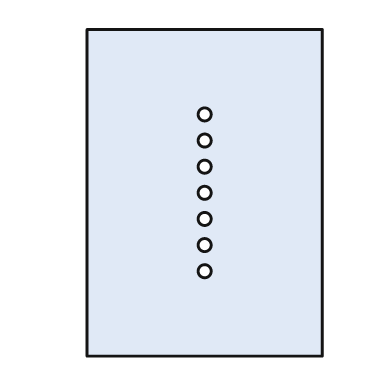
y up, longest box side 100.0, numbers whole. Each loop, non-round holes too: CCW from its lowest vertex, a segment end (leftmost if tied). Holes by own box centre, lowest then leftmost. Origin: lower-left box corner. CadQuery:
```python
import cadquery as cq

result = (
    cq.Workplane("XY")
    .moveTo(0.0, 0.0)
    .lineTo(72.0, 0.0)
    .lineTo(72.0, 100.0)
    .lineTo(0.0, 100.0)
    .close()
    .moveTo(36.0, 26.0)
    .circle(2.0)
    .moveTo(36.0, 34.0)
    .circle(2.0)
    .moveTo(36.0, 42.0)
    .circle(2.0)
    .moveTo(36.0, 50.0)
    .circle(2.0)
    .moveTo(36.0, 58.0)
    .circle(2.0)
    .moveTo(36.0, 66.0)
    .circle(2.0)
    .moveTo(36.0, 74.0)
    .circle(2.0)
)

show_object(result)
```